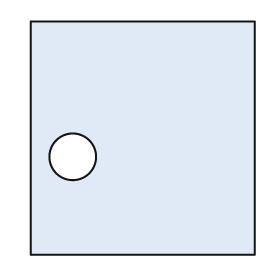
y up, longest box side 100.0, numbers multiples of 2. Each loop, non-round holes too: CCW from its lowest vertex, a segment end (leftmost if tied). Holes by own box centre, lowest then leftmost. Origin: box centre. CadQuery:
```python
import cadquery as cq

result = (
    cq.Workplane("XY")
    .moveTo(-48.0, -50.0)
    .lineTo(48.0, -50.0)
    .lineTo(48.0, 50.0)
    .lineTo(-48.0, 50.0)
    .close()
    .moveTo(-30.0, -8.0)
    .circle(10.0)
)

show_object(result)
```